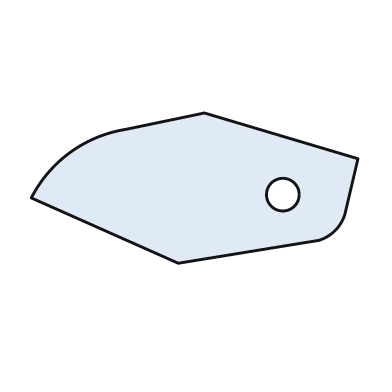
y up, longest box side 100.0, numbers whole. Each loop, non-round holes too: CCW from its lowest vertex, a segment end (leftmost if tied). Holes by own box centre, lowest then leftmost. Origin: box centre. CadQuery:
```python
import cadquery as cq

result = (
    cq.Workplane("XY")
    .moveTo(-5.0, -23.0)
    .lineTo(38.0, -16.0)
    .threePointArc((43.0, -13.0), (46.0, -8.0))
    .lineTo(50.0, 9.0)
    .lineTo(3.0, 23.0)
    .lineTo(-21.0, 18.0)
    .threePointArc((-38.0, 11.0), (-50.0, -3.0))
    .close()
    .moveTo(27.0, -2.0)
    .circle(5.0)
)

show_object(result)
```